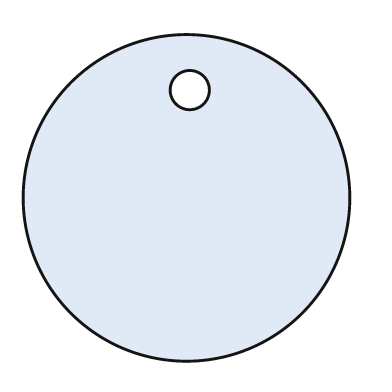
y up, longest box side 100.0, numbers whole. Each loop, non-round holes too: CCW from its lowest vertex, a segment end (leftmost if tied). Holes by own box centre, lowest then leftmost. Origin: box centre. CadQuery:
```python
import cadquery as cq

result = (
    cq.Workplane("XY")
    .moveTo(0.0, 0.0)
    .circle(50.0)
    .moveTo(1.0, 33.0)
    .circle(6.0)
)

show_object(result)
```